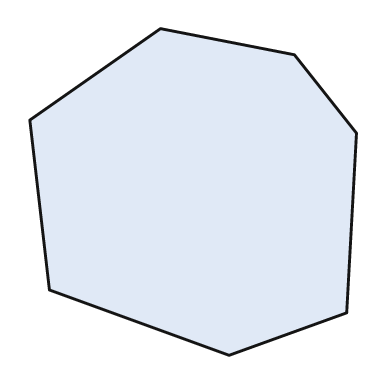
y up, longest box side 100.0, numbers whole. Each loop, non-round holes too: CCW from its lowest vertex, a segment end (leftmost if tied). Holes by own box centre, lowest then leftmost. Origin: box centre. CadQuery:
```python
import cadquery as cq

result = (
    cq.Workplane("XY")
    .moveTo(11.0, -50.0)
    .lineTo(47.0, -37.0)
    .lineTo(50.0, 18.0)
    .lineTo(31.0, 42.0)
    .lineTo(-10.0, 50.0)
    .lineTo(-50.0, 22.0)
    .lineTo(-44.0, -30.0)
    .close()
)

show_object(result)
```